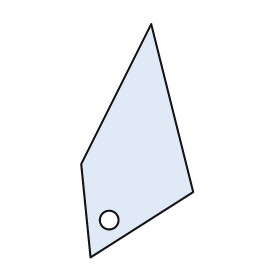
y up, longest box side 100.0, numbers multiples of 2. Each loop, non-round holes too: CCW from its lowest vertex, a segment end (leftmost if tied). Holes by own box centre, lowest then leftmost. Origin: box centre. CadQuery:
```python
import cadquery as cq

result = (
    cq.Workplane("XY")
    .moveTo(-20.0, -50.0)
    .lineTo(24.0, -22.0)
    .lineTo(6.0, 50.0)
    .lineTo(-24.0, -10.0)
    .close()
    .moveTo(-12.0, -34.0)
    .circle(4.0)
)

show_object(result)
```